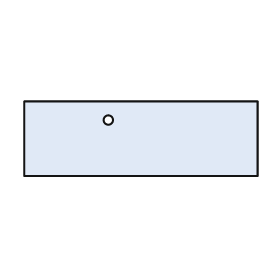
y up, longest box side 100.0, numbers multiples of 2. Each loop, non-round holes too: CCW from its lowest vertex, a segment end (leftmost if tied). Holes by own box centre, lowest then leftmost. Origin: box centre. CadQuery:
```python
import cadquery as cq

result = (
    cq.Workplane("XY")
    .moveTo(-50.0, -16.0)
    .lineTo(50.0, -16.0)
    .lineTo(50.0, 16.0)
    .lineTo(-50.0, 16.0)
    .close()
    .moveTo(-14.0, 8.0)
    .circle(2.0)
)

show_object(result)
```